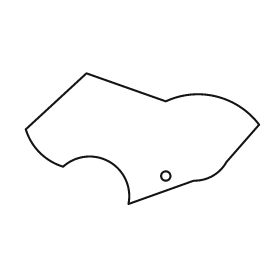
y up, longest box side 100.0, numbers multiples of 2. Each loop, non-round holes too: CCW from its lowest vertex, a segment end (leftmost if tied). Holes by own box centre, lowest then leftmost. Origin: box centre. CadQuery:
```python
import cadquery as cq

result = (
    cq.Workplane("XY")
    .moveTo(-6.0, -28.0)
    .lineTo(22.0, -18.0)
    .threePointArc((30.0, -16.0), (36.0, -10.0))
    .lineTo(50.0, 6.0)
    .threePointArc((32.0, 18.0), (10.0, 16.0))
    .lineTo(-24.0, 28.0)
    .lineTo(-50.0, 4.0)
    .threePointArc((-44.0, -6.0), (-34.0, -12.0))
    .threePointArc((-14.0, -10.0), (-6.0, -28.0))
    .close()
    .moveTo(10.0, -16.0)
    .circle(2.0)
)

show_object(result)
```